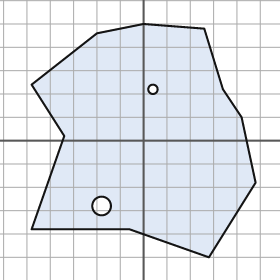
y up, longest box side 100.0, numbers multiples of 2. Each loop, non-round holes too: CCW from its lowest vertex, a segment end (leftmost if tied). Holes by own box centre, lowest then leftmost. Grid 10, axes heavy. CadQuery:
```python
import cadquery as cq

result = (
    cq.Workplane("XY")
    .moveTo(28.0, -50.0)
    .lineTo(48.0, -18.0)
    .lineTo(42.0, 10.0)
    .lineTo(34.0, 22.0)
    .lineTo(26.0, 48.0)
    .lineTo(0.0, 50.0)
    .lineTo(-20.0, 46.0)
    .lineTo(-48.0, 24.0)
    .lineTo(-34.0, 2.0)
    .lineTo(-48.0, -38.0)
    .lineTo(-6.0, -38.0)
    .close()
    .moveTo(-18.0, -28.0)
    .circle(4.0)
    .moveTo(4.0, 22.0)
    .circle(2.0)
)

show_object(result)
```